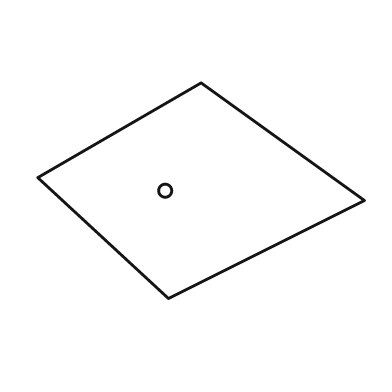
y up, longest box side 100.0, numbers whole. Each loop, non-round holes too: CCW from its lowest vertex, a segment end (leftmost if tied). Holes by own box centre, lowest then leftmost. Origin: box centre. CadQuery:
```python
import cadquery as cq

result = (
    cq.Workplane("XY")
    .moveTo(-10.0, -33.0)
    .lineTo(50.0, -3.0)
    .lineTo(0.0, 33.0)
    .lineTo(-50.0, 4.0)
    .close()
    .moveTo(-11.0, 0.0)
    .circle(2.0)
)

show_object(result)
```